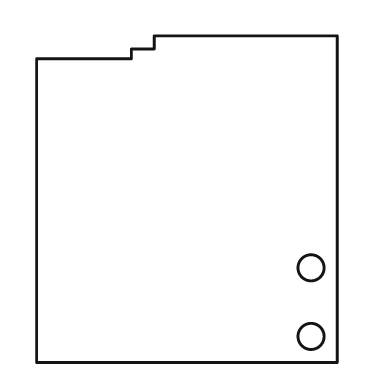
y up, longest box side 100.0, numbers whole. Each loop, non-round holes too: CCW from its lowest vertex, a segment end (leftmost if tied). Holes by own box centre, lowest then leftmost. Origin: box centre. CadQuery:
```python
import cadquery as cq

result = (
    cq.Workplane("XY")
    .moveTo(-46.0, -50.0)
    .lineTo(46.0, -50.0)
    .lineTo(46.0, 50.0)
    .lineTo(-10.0, 50.0)
    .lineTo(-10.0, 46.0)
    .lineTo(-17.0, 46.0)
    .lineTo(-17.0, 43.0)
    .lineTo(-46.0, 43.0)
    .close()
    .moveTo(38.0, -42.0)
    .circle(4.0)
    .moveTo(38.0, -21.0)
    .circle(4.0)
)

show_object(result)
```